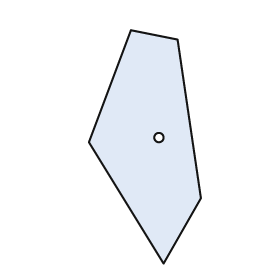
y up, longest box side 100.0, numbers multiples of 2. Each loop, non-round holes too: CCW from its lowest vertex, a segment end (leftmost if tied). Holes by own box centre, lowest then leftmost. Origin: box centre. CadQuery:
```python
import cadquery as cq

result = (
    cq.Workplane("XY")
    .moveTo(8.0, -50.0)
    .lineTo(24.0, -22.0)
    .lineTo(14.0, 46.0)
    .lineTo(-6.0, 50.0)
    .lineTo(-24.0, 2.0)
    .close()
    .moveTo(6.0, 4.0)
    .circle(2.0)
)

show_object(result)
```